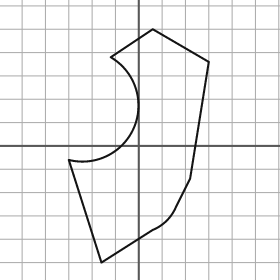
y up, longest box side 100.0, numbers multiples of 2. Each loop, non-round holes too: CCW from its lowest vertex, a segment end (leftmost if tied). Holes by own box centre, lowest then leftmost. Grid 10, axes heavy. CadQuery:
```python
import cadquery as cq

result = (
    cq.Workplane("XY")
    .moveTo(-16.0, -50.0)
    .lineTo(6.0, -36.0)
    .threePointArc((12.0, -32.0), (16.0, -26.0))
    .lineTo(22.0, -14.0)
    .lineTo(30.0, 36.0)
    .lineTo(6.0, 50.0)
    .lineTo(-12.0, 38.0)
    .threePointArc((-2.0, 8.0), (-30.0, -6.0))
    .close()
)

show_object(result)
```